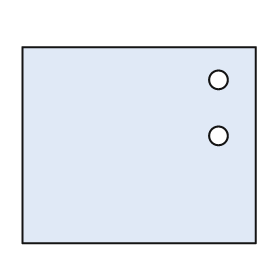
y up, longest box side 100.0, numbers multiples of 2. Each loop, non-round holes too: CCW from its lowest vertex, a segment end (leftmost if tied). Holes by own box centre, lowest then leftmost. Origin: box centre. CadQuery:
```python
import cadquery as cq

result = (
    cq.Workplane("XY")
    .moveTo(-50.0, -42.0)
    .lineTo(50.0, -42.0)
    .lineTo(50.0, 42.0)
    .lineTo(-50.0, 42.0)
    .close()
    .moveTo(34.0, 4.0)
    .circle(4.0)
    .moveTo(34.0, 28.0)
    .circle(4.0)
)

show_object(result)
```